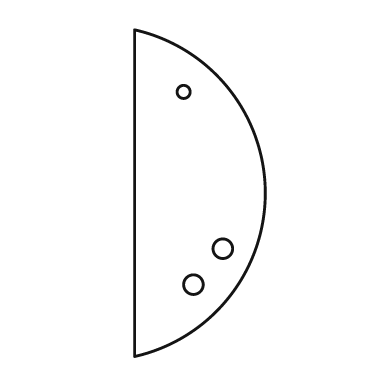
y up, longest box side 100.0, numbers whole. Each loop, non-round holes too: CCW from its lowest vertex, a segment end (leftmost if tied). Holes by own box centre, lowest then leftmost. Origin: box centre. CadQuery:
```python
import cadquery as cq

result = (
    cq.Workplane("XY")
    .moveTo(-20.0, -50.0)
    .threePointArc((20.0, 0.0), (-20.0, 50.0))
    .close()
    .moveTo(-2.0, -28.0)
    .circle(3.0)
    .moveTo(7.0, -17.0)
    .circle(3.0)
    .moveTo(-5.0, 31.0)
    .circle(2.0)
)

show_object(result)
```